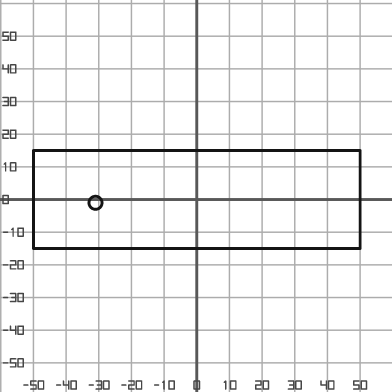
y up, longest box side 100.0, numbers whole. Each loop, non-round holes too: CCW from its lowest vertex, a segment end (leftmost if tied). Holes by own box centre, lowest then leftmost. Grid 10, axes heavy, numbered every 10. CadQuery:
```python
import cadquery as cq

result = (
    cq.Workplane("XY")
    .moveTo(-50.0, -15.0)
    .lineTo(50.0, -15.0)
    .lineTo(50.0, 15.0)
    .lineTo(-50.0, 15.0)
    .close()
    .moveTo(-31.0, -1.0)
    .circle(2.0)
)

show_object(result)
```